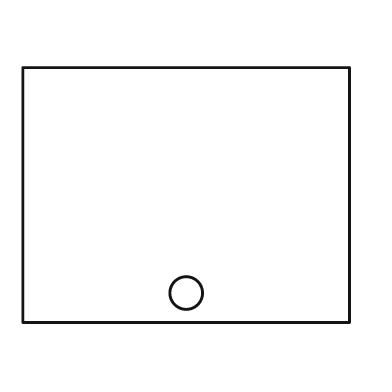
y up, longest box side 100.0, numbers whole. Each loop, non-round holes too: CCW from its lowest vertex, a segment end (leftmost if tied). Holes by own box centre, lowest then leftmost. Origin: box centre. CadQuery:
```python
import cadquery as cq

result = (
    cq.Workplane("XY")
    .moveTo(-50.0, -39.0)
    .lineTo(50.0, -39.0)
    .lineTo(50.0, 39.0)
    .lineTo(-50.0, 39.0)
    .close()
    .moveTo(0.0, -30.0)
    .circle(5.0)
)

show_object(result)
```